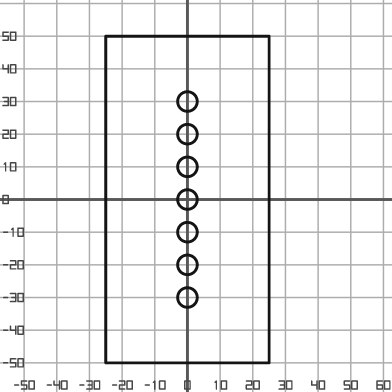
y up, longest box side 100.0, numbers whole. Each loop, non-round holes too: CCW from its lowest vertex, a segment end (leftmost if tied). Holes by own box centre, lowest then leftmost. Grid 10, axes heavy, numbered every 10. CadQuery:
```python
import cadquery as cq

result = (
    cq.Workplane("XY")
    .moveTo(-25.0, -50.0)
    .lineTo(25.0, -50.0)
    .lineTo(25.0, 50.0)
    .lineTo(-25.0, 50.0)
    .close()
    .moveTo(0.0, -30.0)
    .circle(3.0)
    .moveTo(0.0, -20.0)
    .circle(3.0)
    .moveTo(0.0, -10.0)
    .circle(3.0)
    .moveTo(0.0, 0.0)
    .circle(3.0)
    .moveTo(0.0, 10.0)
    .circle(3.0)
    .moveTo(0.0, 20.0)
    .circle(3.0)
    .moveTo(0.0, 30.0)
    .circle(3.0)
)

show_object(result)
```